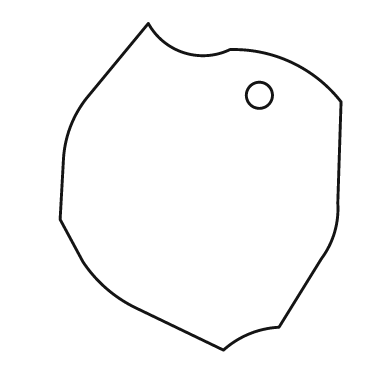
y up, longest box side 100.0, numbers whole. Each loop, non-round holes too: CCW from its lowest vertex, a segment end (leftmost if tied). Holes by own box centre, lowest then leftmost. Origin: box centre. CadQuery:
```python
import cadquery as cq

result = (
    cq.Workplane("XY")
    .moveTo(7.0, -50.0)
    .threePointArc((15.0, -45.0), (24.0, -43.0))
    .lineTo(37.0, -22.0)
    .threePointArc((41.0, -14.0), (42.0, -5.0))
    .lineTo(43.0, 26.0)
    .threePointArc((28.0, 38.0), (9.0, 42.0))
    .threePointArc((-5.0, 41.0), (-16.0, 50.0))
    .lineTo(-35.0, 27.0)
    .threePointArc((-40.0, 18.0), (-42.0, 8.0))
    .lineTo(-43.0, -10.0)
    .lineTo(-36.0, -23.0)
    .threePointArc((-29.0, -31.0), (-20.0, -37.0))
    .close()
    .moveTo(18.0, 28.0)
    .circle(4.0)
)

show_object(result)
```